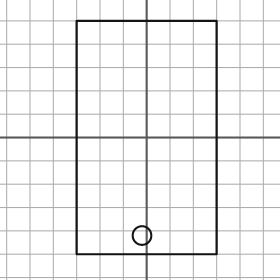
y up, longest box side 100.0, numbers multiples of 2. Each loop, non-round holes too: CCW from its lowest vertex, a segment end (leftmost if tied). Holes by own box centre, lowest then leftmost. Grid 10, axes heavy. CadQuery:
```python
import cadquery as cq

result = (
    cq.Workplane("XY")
    .moveTo(-30.0, -50.0)
    .lineTo(30.0, -50.0)
    .lineTo(30.0, 50.0)
    .lineTo(-30.0, 50.0)
    .close()
    .moveTo(-2.0, -42.0)
    .circle(4.0)
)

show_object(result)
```